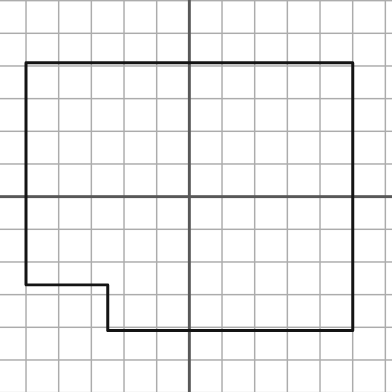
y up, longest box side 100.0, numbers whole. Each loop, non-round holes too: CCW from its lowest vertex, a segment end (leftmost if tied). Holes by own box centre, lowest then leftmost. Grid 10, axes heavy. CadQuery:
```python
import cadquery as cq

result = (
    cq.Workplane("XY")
    .moveTo(-25.0, -41.0)
    .lineTo(50.0, -41.0)
    .lineTo(50.0, 41.0)
    .lineTo(-50.0, 41.0)
    .lineTo(-50.0, -27.0)
    .lineTo(-25.0, -27.0)
    .close()
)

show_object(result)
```